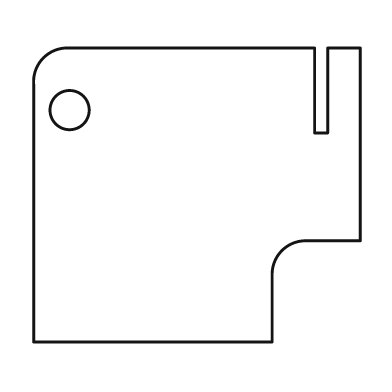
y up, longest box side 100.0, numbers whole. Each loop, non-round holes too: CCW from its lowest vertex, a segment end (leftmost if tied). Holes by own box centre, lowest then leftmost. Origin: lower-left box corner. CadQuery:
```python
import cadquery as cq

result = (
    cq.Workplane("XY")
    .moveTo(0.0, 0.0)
    .lineTo(73.0, 0.0)
    .lineTo(73.0, 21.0)
    .threePointArc((76.0, 28.0), (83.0, 31.0))
    .lineTo(100.0, 31.0)
    .lineTo(100.0, 90.0)
    .lineTo(90.0, 90.0)
    .lineTo(90.0, 64.0)
    .lineTo(86.0, 64.0)
    .lineTo(86.0, 90.0)
    .lineTo(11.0, 90.0)
    .threePointArc((3.0, 87.0), (0.0, 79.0))
    .close()
    .moveTo(11.0, 71.0)
    .circle(6.0)
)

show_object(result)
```